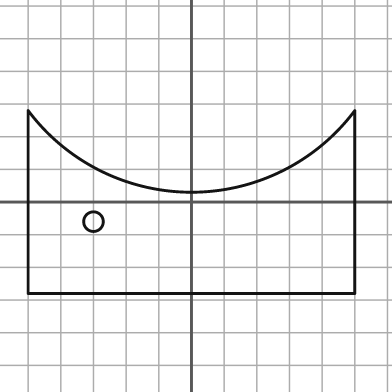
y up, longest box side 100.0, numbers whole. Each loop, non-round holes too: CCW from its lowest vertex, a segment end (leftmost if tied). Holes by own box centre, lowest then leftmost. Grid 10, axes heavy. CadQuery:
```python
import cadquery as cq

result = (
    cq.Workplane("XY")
    .moveTo(-50.0, -28.0)
    .lineTo(50.0, -28.0)
    .lineTo(50.0, 28.0)
    .threePointArc((0.0, 3.0), (-50.0, 28.0))
    .close()
    .moveTo(-30.0, -6.0)
    .circle(3.0)
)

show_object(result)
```